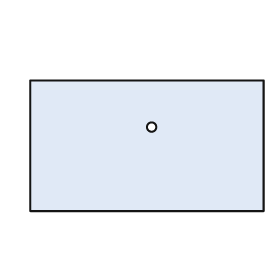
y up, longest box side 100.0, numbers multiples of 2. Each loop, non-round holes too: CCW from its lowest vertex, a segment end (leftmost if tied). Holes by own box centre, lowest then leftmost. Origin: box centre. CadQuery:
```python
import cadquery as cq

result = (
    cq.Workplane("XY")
    .moveTo(-50.0, -28.0)
    .lineTo(50.0, -28.0)
    .lineTo(50.0, 28.0)
    .lineTo(-50.0, 28.0)
    .close()
    .moveTo(2.0, 8.0)
    .circle(2.0)
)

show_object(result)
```